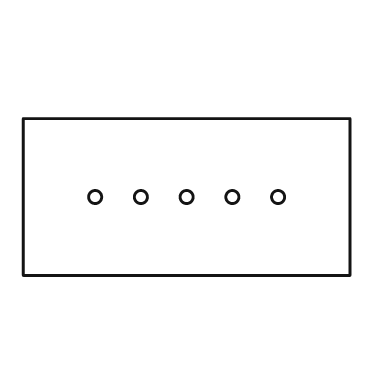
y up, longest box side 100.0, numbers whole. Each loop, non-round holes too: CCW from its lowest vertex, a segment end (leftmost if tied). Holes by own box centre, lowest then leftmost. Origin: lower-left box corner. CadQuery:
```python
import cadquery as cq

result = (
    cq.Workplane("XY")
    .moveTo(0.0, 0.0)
    .lineTo(100.0, 0.0)
    .lineTo(100.0, 48.0)
    .lineTo(0.0, 48.0)
    .close()
    .moveTo(22.0, 24.0)
    .circle(2.0)
    .moveTo(36.0, 24.0)
    .circle(2.0)
    .moveTo(50.0, 24.0)
    .circle(2.0)
    .moveTo(64.0, 24.0)
    .circle(2.0)
    .moveTo(78.0, 24.0)
    .circle(2.0)
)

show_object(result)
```